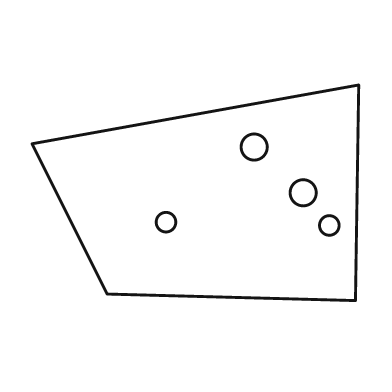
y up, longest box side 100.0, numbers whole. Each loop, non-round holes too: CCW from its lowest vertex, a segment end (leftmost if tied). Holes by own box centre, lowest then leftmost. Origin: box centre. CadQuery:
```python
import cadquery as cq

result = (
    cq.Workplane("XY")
    .moveTo(49.0, -33.0)
    .lineTo(50.0, 33.0)
    .lineTo(-50.0, 15.0)
    .lineTo(-27.0, -31.0)
    .close()
    .moveTo(41.0, -10.0)
    .circle(3.0)
    .moveTo(-9.0, -9.0)
    .circle(3.0)
    .moveTo(33.0, 0.0)
    .circle(4.0)
    .moveTo(18.0, 14.0)
    .circle(4.0)
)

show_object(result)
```